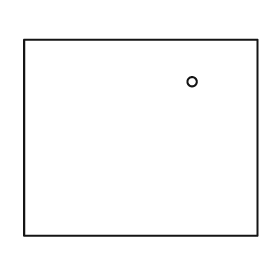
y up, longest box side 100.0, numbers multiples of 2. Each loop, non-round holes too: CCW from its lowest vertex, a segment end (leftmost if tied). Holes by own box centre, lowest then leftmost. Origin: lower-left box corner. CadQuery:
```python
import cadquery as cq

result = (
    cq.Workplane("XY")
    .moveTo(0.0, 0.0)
    .lineTo(100.0, 0.0)
    .lineTo(100.0, 84.0)
    .lineTo(0.0, 84.0)
    .close()
    .moveTo(72.0, 66.0)
    .circle(2.0)
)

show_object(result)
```